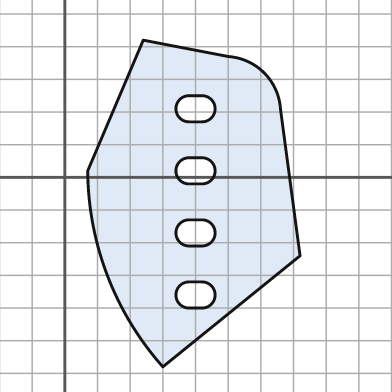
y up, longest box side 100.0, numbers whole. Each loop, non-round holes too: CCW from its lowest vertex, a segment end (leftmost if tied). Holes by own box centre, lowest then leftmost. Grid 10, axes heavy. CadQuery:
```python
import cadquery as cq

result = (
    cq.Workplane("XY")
    .moveTo(30.0, -58.0)
    .lineTo(72.0, -24.0)
    .lineTo(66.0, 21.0)
    .threePointArc((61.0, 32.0), (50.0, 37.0))
    .lineTo(24.0, 42.0)
    .lineTo(7.0, 2.0)
    .threePointArc((13.0, -30.0), (30.0, -58.0))
    .close()
    .moveTo(38.0, -40.0)
    .lineTo(42.0, -40.0)
    .threePointArc((46.0, -36.0), (42.0, -32.0))
    .lineTo(38.0, -32.0)
    .threePointArc((34.0, -36.0), (38.0, -40.0))
    .close()
    .moveTo(38.0, -21.0)
    .lineTo(42.0, -21.0)
    .threePointArc((46.0, -17.0), (42.0, -13.0))
    .lineTo(38.0, -13.0)
    .threePointArc((34.0, -17.0), (38.0, -21.0))
    .close()
    .moveTo(38.0, -2.0)
    .lineTo(42.0, -2.0)
    .threePointArc((46.0, 2.0), (42.0, 6.0))
    .lineTo(38.0, 6.0)
    .threePointArc((34.0, 2.0), (38.0, -2.0))
    .close()
    .moveTo(38.0, 17.0)
    .lineTo(42.0, 17.0)
    .threePointArc((46.0, 21.0), (42.0, 25.0))
    .lineTo(38.0, 25.0)
    .threePointArc((34.0, 21.0), (38.0, 17.0))
    .close()
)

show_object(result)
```